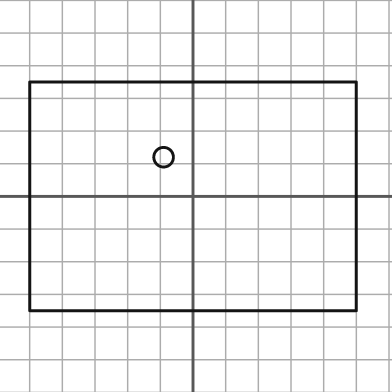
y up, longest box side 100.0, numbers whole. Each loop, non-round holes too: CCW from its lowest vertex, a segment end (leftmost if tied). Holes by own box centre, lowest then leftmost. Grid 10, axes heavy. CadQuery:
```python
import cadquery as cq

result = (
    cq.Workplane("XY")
    .moveTo(-50.0, -35.0)
    .lineTo(50.0, -35.0)
    .lineTo(50.0, 35.0)
    .lineTo(-50.0, 35.0)
    .close()
    .moveTo(-9.0, 12.0)
    .circle(3.0)
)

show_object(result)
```